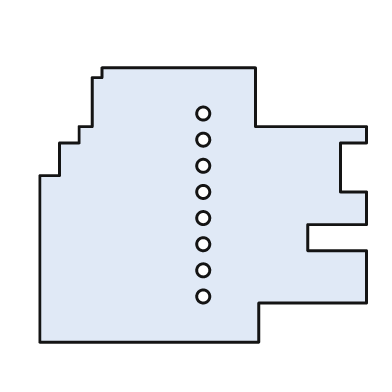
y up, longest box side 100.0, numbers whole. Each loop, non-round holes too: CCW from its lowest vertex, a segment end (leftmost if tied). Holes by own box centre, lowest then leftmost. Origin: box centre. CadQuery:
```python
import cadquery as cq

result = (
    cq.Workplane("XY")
    .moveTo(-50.0, -42.0)
    .lineTo(17.0, -42.0)
    .lineTo(17.0, -30.0)
    .lineTo(50.0, -30.0)
    .lineTo(50.0, -14.0)
    .lineTo(32.0, -14.0)
    .lineTo(32.0, -6.0)
    .lineTo(50.0, -6.0)
    .lineTo(50.0, 4.0)
    .lineTo(42.0, 4.0)
    .lineTo(42.0, 19.0)
    .lineTo(50.0, 19.0)
    .lineTo(50.0, 24.0)
    .lineTo(16.0, 24.0)
    .lineTo(16.0, 42.0)
    .lineTo(-31.0, 42.0)
    .lineTo(-31.0, 39.0)
    .lineTo(-34.0, 39.0)
    .lineTo(-34.0, 24.0)
    .lineTo(-38.0, 24.0)
    .lineTo(-38.0, 19.0)
    .lineTo(-44.0, 19.0)
    .lineTo(-44.0, 9.0)
    .lineTo(-50.0, 9.0)
    .close()
    .moveTo(0.0, -28.0)
    .circle(2.0)
    .moveTo(0.0, -20.0)
    .circle(2.0)
    .moveTo(0.0, -12.0)
    .circle(2.0)
    .moveTo(0.0, -4.0)
    .circle(2.0)
    .moveTo(0.0, 4.0)
    .circle(2.0)
    .moveTo(0.0, 12.0)
    .circle(2.0)
    .moveTo(0.0, 20.0)
    .circle(2.0)
    .moveTo(0.0, 28.0)
    .circle(2.0)
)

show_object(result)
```